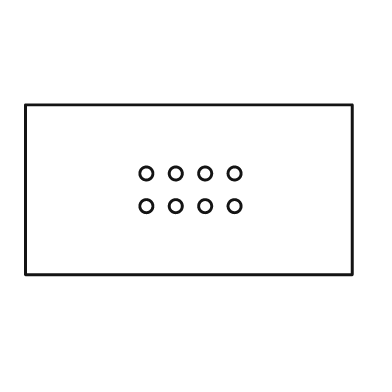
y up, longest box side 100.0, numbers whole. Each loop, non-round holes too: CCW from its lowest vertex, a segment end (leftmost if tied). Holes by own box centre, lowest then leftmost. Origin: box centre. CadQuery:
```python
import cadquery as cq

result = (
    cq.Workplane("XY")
    .moveTo(-50.0, -26.0)
    .lineTo(50.0, -26.0)
    .lineTo(50.0, 26.0)
    .lineTo(-50.0, 26.0)
    .close()
    .moveTo(-13.0, -5.0)
    .circle(2.0)
    .moveTo(-4.0, -5.0)
    .circle(2.0)
    .moveTo(5.0, -5.0)
    .circle(2.0)
    .moveTo(14.0, -5.0)
    .circle(2.0)
    .moveTo(-13.0, 5.0)
    .circle(2.0)
    .moveTo(-4.0, 5.0)
    .circle(2.0)
    .moveTo(5.0, 5.0)
    .circle(2.0)
    .moveTo(14.0, 5.0)
    .circle(2.0)
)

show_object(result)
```